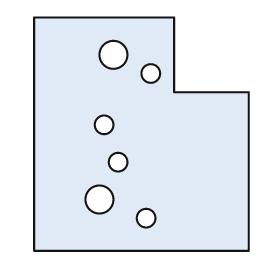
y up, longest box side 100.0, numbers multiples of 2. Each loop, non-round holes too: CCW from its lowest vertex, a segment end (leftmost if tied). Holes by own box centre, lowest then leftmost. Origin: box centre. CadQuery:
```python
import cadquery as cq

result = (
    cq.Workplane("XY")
    .moveTo(-46.0, -50.0)
    .lineTo(46.0, -50.0)
    .lineTo(46.0, 18.0)
    .lineTo(14.0, 18.0)
    .lineTo(14.0, 50.0)
    .lineTo(-46.0, 50.0)
    .close()
    .moveTo(2.0, -36.0)
    .circle(4.0)
    .moveTo(-18.0, -28.0)
    .circle(6.0)
    .moveTo(-10.0, -12.0)
    .circle(4.0)
    .moveTo(-16.0, 4.0)
    .circle(4.0)
    .moveTo(4.0, 26.0)
    .circle(4.0)
    .moveTo(-12.0, 34.0)
    .circle(6.0)
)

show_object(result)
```